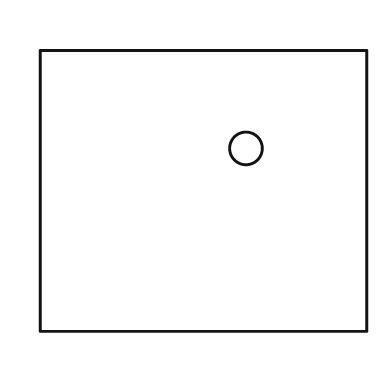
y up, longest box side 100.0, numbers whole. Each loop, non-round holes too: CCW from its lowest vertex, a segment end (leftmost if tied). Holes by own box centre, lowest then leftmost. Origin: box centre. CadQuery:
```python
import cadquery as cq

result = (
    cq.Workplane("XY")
    .moveTo(-50.0, -43.0)
    .lineTo(50.0, -43.0)
    .lineTo(50.0, 43.0)
    .lineTo(-50.0, 43.0)
    .close()
    .moveTo(13.0, 13.0)
    .circle(5.0)
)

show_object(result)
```